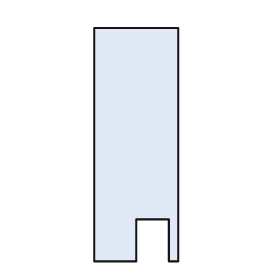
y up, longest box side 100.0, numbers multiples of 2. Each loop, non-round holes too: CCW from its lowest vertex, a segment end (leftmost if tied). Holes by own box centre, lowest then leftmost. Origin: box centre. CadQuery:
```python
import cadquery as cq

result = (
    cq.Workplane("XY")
    .moveTo(-18.0, -50.0)
    .lineTo(0.0, -50.0)
    .lineTo(0.0, -32.0)
    .lineTo(14.0, -32.0)
    .lineTo(14.0, -50.0)
    .lineTo(18.0, -50.0)
    .lineTo(18.0, 50.0)
    .lineTo(-18.0, 50.0)
    .close()
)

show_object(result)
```